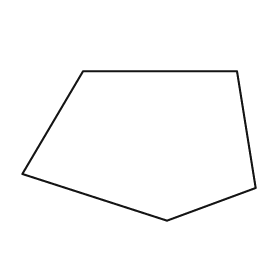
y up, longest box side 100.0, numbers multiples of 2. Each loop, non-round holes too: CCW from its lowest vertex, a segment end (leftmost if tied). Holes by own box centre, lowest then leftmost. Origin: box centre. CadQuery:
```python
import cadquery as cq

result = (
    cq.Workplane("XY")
    .moveTo(12.0, -32.0)
    .lineTo(50.0, -18.0)
    .lineTo(42.0, 32.0)
    .lineTo(-24.0, 32.0)
    .lineTo(-50.0, -12.0)
    .close()
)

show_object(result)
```